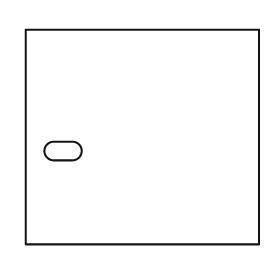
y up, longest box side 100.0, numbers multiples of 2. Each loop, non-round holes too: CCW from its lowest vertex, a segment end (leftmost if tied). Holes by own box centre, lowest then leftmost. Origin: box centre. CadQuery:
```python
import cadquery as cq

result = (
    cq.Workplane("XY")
    .moveTo(-50.0, -46.0)
    .lineTo(50.0, -46.0)
    .lineTo(50.0, 46.0)
    .lineTo(-50.0, 46.0)
    .close()
    .moveTo(-38.0, -10.0)
    .lineTo(-30.0, -10.0)
    .threePointArc((-26.0, -6.0), (-30.0, -2.0))
    .lineTo(-38.0, -2.0)
    .threePointArc((-42.0, -6.0), (-38.0, -10.0))
    .close()
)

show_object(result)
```